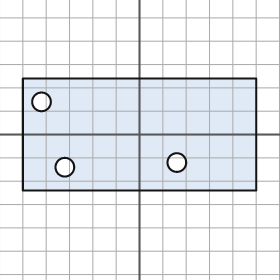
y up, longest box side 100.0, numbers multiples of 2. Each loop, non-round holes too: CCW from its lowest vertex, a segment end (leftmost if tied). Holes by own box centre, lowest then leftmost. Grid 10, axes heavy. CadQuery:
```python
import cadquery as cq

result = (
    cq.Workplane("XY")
    .moveTo(-50.0, -24.0)
    .lineTo(50.0, -24.0)
    .lineTo(50.0, 24.0)
    .lineTo(-50.0, 24.0)
    .close()
    .moveTo(-32.0, -14.0)
    .circle(4.0)
    .moveTo(16.0, -12.0)
    .circle(4.0)
    .moveTo(-42.0, 14.0)
    .circle(4.0)
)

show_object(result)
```